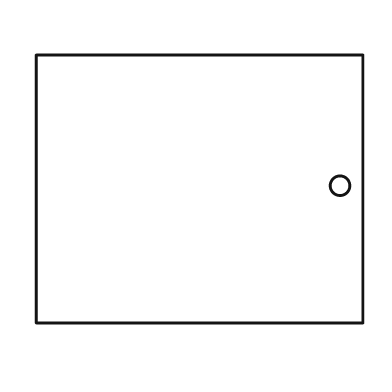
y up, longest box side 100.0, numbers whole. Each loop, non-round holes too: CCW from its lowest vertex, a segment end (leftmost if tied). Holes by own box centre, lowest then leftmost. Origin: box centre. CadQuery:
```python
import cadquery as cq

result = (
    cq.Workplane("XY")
    .moveTo(-50.0, -41.0)
    .lineTo(50.0, -41.0)
    .lineTo(50.0, 41.0)
    .lineTo(-50.0, 41.0)
    .close()
    .moveTo(43.0, 1.0)
    .circle(3.0)
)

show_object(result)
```